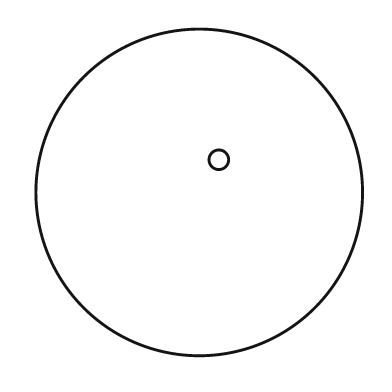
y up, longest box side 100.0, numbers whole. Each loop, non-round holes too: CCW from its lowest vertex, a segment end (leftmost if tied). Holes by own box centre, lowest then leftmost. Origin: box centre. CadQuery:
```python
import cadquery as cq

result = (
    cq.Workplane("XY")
    .moveTo(0.0, 0.0)
    .circle(50.0)
    .moveTo(6.0, 10.0)
    .circle(3.0)
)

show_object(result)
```